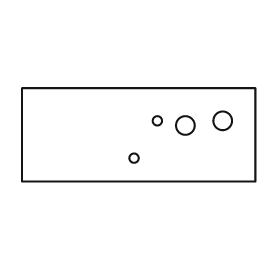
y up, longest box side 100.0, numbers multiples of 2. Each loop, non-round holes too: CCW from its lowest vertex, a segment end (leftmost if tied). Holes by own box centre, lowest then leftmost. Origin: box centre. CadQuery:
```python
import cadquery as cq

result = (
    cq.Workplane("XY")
    .moveTo(-50.0, -20.0)
    .lineTo(50.0, -20.0)
    .lineTo(50.0, 20.0)
    .lineTo(-50.0, 20.0)
    .close()
    .moveTo(-2.0, -10.0)
    .circle(2.0)
    .moveTo(20.0, 4.0)
    .circle(4.0)
    .moveTo(8.0, 6.0)
    .circle(2.0)
    .moveTo(36.0, 6.0)
    .circle(4.0)
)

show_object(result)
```